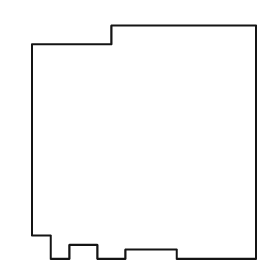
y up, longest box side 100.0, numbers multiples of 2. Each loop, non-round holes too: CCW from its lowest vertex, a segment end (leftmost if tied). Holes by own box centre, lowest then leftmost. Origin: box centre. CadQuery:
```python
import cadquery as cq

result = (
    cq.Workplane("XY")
    .moveTo(-40.0, -50.0)
    .lineTo(-32.0, -50.0)
    .lineTo(-32.0, -44.0)
    .lineTo(-20.0, -44.0)
    .lineTo(-20.0, -50.0)
    .lineTo(-8.0, -50.0)
    .lineTo(-8.0, -46.0)
    .lineTo(14.0, -46.0)
    .lineTo(14.0, -50.0)
    .lineTo(48.0, -50.0)
    .lineTo(48.0, 50.0)
    .lineTo(-14.0, 50.0)
    .lineTo(-14.0, 42.0)
    .lineTo(-48.0, 42.0)
    .lineTo(-48.0, -40.0)
    .lineTo(-40.0, -40.0)
    .close()
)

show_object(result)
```